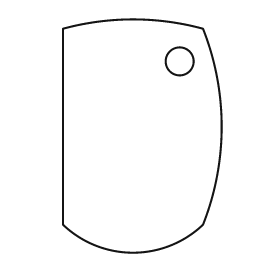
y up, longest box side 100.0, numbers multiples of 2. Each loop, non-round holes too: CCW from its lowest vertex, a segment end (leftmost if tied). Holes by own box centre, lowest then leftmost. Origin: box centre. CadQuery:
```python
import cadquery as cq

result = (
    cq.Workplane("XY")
    .moveTo(-34.0, -38.0)
    .threePointArc((-4.0, -50.0), (26.0, -38.0))
    .threePointArc((34.0, 4.0), (26.0, 46.0))
    .threePointArc((-4.0, 50.0), (-34.0, 46.0))
    .close()
    .moveTo(16.0, 32.0)
    .circle(6.0)
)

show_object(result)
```